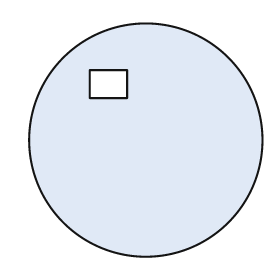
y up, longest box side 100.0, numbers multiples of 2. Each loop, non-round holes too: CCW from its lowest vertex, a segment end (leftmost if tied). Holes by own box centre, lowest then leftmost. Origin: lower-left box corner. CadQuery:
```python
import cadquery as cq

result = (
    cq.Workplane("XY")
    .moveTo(50.0, 50.0)
    .circle(50.0)
    .moveTo(26.0, 68.0)
    .lineTo(42.0, 68.0)
    .lineTo(42.0, 80.0)
    .lineTo(26.0, 80.0)
    .close()
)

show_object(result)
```